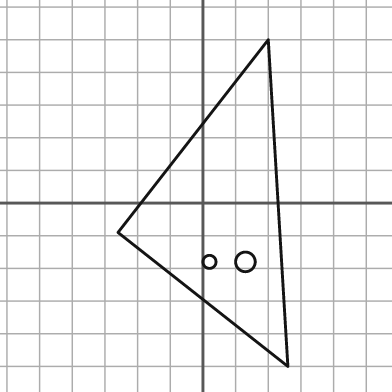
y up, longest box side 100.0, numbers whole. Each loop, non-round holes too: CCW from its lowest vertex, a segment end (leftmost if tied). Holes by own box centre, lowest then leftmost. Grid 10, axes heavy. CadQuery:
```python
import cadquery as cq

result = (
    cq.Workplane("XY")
    .moveTo(26.0, -50.0)
    .lineTo(20.0, 50.0)
    .lineTo(-26.0, -9.0)
    .close()
    .moveTo(2.0, -18.0)
    .circle(2.0)
    .moveTo(13.0, -18.0)
    .circle(3.0)
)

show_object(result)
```